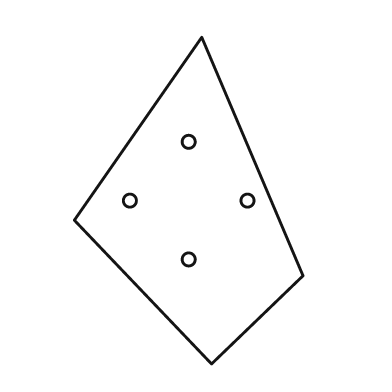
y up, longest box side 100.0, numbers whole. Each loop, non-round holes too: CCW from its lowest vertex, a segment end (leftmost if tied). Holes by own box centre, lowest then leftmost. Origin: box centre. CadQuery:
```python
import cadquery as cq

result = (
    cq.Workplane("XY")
    .moveTo(7.0, -50.0)
    .lineTo(35.0, -23.0)
    .lineTo(4.0, 50.0)
    .lineTo(-35.0, -6.0)
    .close()
    .moveTo(0.0, -18.0)
    .circle(2.0)
    .moveTo(-18.0, 0.0)
    .circle(2.0)
    .moveTo(18.0, 0.0)
    .circle(2.0)
    .moveTo(0.0, 18.0)
    .circle(2.0)
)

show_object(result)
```